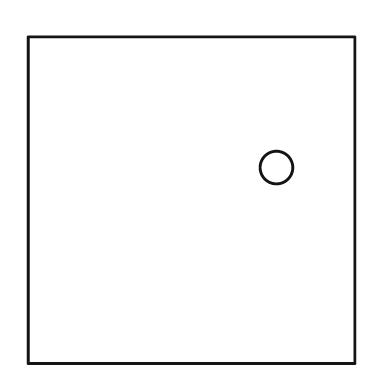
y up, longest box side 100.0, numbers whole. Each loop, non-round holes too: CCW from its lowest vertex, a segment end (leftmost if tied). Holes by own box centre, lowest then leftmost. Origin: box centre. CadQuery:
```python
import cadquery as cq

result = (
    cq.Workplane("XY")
    .moveTo(-50.0, -50.0)
    .lineTo(50.0, -50.0)
    .lineTo(50.0, 50.0)
    .lineTo(-50.0, 50.0)
    .close()
    .moveTo(26.0, 10.0)
    .circle(5.0)
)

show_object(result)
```